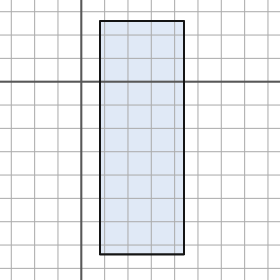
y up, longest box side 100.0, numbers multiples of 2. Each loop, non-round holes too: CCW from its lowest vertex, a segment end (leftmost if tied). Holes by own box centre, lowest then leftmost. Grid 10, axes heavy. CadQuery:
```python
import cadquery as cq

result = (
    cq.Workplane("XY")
    .moveTo(8.0, -74.0)
    .lineTo(44.0, -74.0)
    .lineTo(44.0, 26.0)
    .lineTo(8.0, 26.0)
    .close()
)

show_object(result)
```